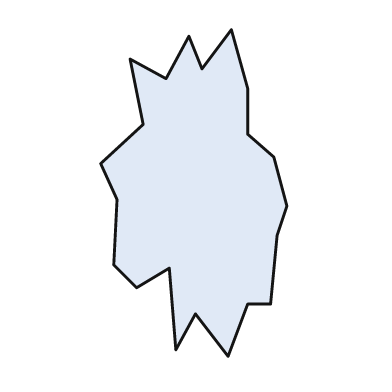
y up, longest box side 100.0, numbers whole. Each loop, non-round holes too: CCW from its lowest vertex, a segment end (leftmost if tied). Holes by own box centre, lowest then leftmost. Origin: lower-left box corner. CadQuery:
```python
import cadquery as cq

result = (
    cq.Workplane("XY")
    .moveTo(39.0, 0.0)
    .lineTo(45.0, 16.0)
    .lineTo(52.0, 16.0)
    .lineTo(54.0, 37.0)
    .lineTo(57.0, 46.0)
    .lineTo(53.0, 61.0)
    .lineTo(45.0, 68.0)
    .lineTo(45.0, 82.0)
    .lineTo(40.0, 100.0)
    .lineTo(31.0, 88.0)
    .lineTo(27.0, 98.0)
    .lineTo(20.0, 85.0)
    .lineTo(9.0, 91.0)
    .lineTo(13.0, 71.0)
    .lineTo(0.0, 59.0)
    .lineTo(5.0, 48.0)
    .lineTo(4.0, 28.0)
    .lineTo(11.0, 21.0)
    .lineTo(21.0, 27.0)
    .lineTo(23.0, 2.0)
    .lineTo(29.0, 13.0)
    .close()
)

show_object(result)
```